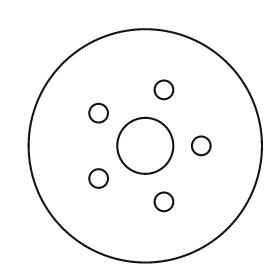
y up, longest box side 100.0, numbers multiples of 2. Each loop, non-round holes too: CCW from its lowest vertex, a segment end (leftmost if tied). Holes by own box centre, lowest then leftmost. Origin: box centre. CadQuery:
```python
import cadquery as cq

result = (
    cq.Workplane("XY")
    .moveTo(0.0, 0.0)
    .circle(50.0)
    .moveTo(8.0, -24.0)
    .circle(4.0)
    .moveTo(-20.0, -14.0)
    .circle(4.0)
    .moveTo(0.0, 0.0)
    .circle(12.0)
    .moveTo(24.0, 0.0)
    .circle(4.0)
    .moveTo(-20.0, 14.0)
    .circle(4.0)
    .moveTo(8.0, 24.0)
    .circle(4.0)
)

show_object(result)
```